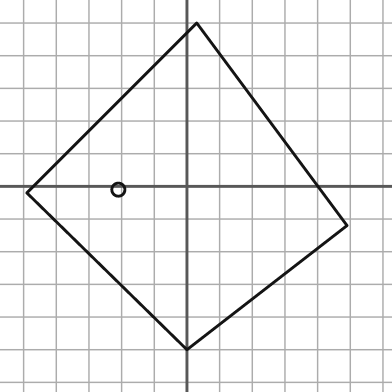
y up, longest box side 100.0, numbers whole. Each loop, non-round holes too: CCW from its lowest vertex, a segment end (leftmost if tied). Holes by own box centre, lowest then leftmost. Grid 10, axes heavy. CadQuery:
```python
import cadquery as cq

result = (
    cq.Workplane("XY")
    .moveTo(0.0, -50.0)
    .lineTo(49.0, -12.0)
    .lineTo(3.0, 50.0)
    .lineTo(-49.0, -2.0)
    .close()
    .moveTo(-21.0, -1.0)
    .circle(2.0)
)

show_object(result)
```